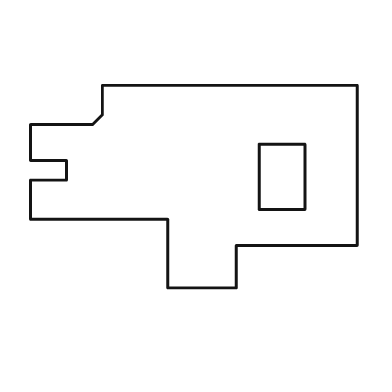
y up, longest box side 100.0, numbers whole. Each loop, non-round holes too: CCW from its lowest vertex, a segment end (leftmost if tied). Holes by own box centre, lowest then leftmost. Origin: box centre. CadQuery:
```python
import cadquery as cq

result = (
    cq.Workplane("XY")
    .moveTo(-8.0, -31.0)
    .lineTo(13.0, -31.0)
    .lineTo(13.0, -18.0)
    .lineTo(50.0, -18.0)
    .lineTo(50.0, 31.0)
    .lineTo(-28.0, 31.0)
    .lineTo(-28.0, 22.0)
    .lineTo(-31.0, 19.0)
    .lineTo(-50.0, 19.0)
    .lineTo(-50.0, 8.0)
    .lineTo(-39.0, 8.0)
    .lineTo(-39.0, 2.0)
    .lineTo(-50.0, 2.0)
    .lineTo(-50.0, -10.0)
    .lineTo(-8.0, -10.0)
    .close()
    .moveTo(20.0, -7.0)
    .lineTo(34.0, -7.0)
    .lineTo(34.0, 13.0)
    .lineTo(20.0, 13.0)
    .close()
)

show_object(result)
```